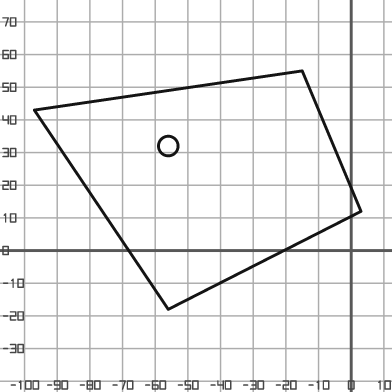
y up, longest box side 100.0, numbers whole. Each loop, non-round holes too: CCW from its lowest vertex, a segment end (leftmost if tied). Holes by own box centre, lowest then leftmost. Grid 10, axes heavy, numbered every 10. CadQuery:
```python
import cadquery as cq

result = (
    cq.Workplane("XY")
    .moveTo(-56.0, -18.0)
    .lineTo(3.0, 12.0)
    .lineTo(-15.0, 55.0)
    .lineTo(-97.0, 43.0)
    .close()
    .moveTo(-56.0, 32.0)
    .circle(3.0)
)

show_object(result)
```